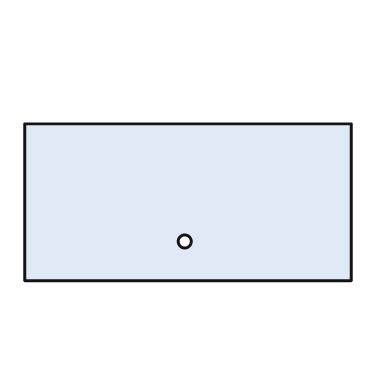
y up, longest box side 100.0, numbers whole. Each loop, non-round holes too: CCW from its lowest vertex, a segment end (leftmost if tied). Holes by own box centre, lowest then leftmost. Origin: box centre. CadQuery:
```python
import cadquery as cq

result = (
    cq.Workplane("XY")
    .moveTo(-50.0, -24.0)
    .lineTo(50.0, -24.0)
    .lineTo(50.0, 24.0)
    .lineTo(-50.0, 24.0)
    .close()
    .moveTo(-1.0, -12.0)
    .circle(2.0)
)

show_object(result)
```